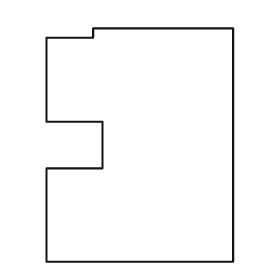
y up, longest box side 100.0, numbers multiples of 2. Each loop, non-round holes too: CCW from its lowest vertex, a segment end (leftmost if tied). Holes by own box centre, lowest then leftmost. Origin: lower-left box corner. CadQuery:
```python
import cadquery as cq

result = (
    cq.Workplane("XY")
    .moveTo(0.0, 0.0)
    .lineTo(80.0, 0.0)
    .lineTo(80.0, 100.0)
    .lineTo(20.0, 100.0)
    .lineTo(20.0, 96.0)
    .lineTo(0.0, 96.0)
    .lineTo(0.0, 60.0)
    .lineTo(24.0, 60.0)
    .lineTo(24.0, 40.0)
    .lineTo(0.0, 40.0)
    .close()
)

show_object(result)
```